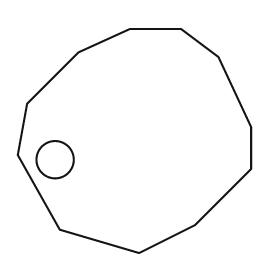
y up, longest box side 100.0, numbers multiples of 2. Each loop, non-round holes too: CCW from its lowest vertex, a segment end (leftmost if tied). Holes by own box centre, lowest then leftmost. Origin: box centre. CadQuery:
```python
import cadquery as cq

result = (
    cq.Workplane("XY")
    .moveTo(2.0, -48.0)
    .lineTo(26.0, -36.0)
    .lineTo(50.0, -12.0)
    .lineTo(50.0, 6.0)
    .lineTo(36.0, 36.0)
    .lineTo(20.0, 48.0)
    .lineTo(-2.0, 48.0)
    .lineTo(-24.0, 38.0)
    .lineTo(-46.0, 16.0)
    .lineTo(-50.0, -6.0)
    .lineTo(-32.0, -38.0)
    .close()
    .moveTo(-34.0, -8.0)
    .circle(8.0)
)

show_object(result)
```